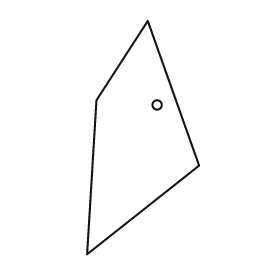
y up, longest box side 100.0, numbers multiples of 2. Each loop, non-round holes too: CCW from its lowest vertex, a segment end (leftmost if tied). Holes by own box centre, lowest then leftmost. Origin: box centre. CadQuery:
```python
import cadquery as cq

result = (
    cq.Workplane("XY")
    .moveTo(-24.0, -50.0)
    .lineTo(24.0, -12.0)
    .lineTo(2.0, 50.0)
    .lineTo(-20.0, 16.0)
    .close()
    .moveTo(6.0, 14.0)
    .circle(2.0)
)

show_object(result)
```